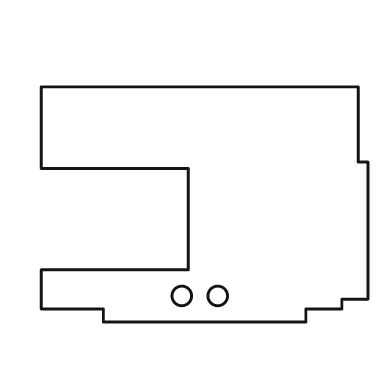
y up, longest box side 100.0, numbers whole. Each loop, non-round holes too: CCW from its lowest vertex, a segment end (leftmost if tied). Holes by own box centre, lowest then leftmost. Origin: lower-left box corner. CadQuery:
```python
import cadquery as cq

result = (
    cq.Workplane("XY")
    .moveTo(19.0, 0.0)
    .lineTo(81.0, 0.0)
    .lineTo(81.0, 4.0)
    .lineTo(92.0, 4.0)
    .lineTo(92.0, 7.0)
    .lineTo(100.0, 7.0)
    .lineTo(100.0, 49.0)
    .lineTo(97.0, 49.0)
    .lineTo(97.0, 72.0)
    .lineTo(0.0, 72.0)
    .lineTo(0.0, 47.0)
    .lineTo(45.0, 47.0)
    .lineTo(45.0, 16.0)
    .lineTo(0.0, 16.0)
    .lineTo(0.0, 4.0)
    .lineTo(19.0, 4.0)
    .close()
    .moveTo(43.0, 8.0)
    .circle(3.0)
    .moveTo(54.0, 8.0)
    .circle(3.0)
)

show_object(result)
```